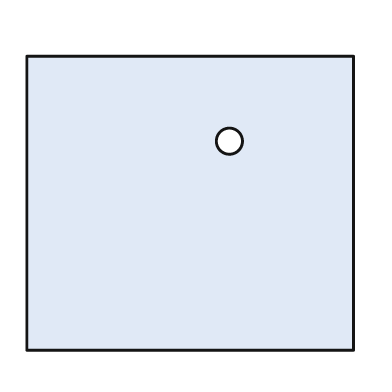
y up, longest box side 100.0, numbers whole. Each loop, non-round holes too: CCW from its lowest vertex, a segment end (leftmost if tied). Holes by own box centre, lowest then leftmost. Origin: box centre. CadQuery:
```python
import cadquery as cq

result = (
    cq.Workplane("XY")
    .moveTo(-50.0, -45.0)
    .lineTo(50.0, -45.0)
    .lineTo(50.0, 45.0)
    .lineTo(-50.0, 45.0)
    .close()
    .moveTo(12.0, 19.0)
    .circle(4.0)
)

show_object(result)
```